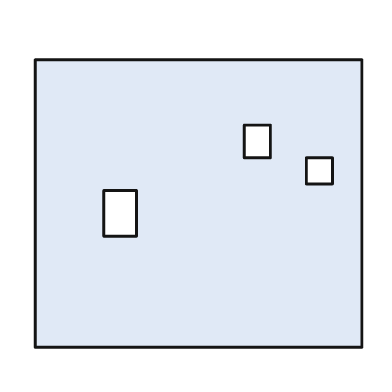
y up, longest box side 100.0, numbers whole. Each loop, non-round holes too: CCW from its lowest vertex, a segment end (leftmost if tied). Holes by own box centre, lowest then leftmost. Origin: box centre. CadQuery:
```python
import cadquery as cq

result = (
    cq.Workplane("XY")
    .moveTo(-50.0, -44.0)
    .lineTo(50.0, -44.0)
    .lineTo(50.0, 44.0)
    .lineTo(-50.0, 44.0)
    .close()
    .moveTo(-29.0, -10.0)
    .lineTo(-19.0, -10.0)
    .lineTo(-19.0, 4.0)
    .lineTo(-29.0, 4.0)
    .close()
    .moveTo(33.0, 6.0)
    .lineTo(41.0, 6.0)
    .lineTo(41.0, 14.0)
    .lineTo(33.0, 14.0)
    .close()
    .moveTo(14.0, 14.0)
    .lineTo(22.0, 14.0)
    .lineTo(22.0, 24.0)
    .lineTo(14.0, 24.0)
    .close()
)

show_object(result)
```